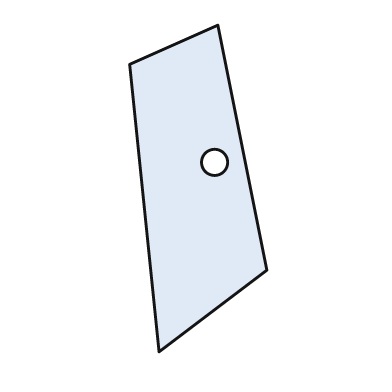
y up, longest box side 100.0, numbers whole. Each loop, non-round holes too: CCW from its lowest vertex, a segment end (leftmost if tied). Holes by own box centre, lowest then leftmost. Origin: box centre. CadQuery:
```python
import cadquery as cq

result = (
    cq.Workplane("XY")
    .moveTo(-12.0, -50.0)
    .lineTo(21.0, -25.0)
    .lineTo(6.0, 50.0)
    .lineTo(-21.0, 38.0)
    .close()
    .moveTo(5.0, 8.0)
    .circle(4.0)
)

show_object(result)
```